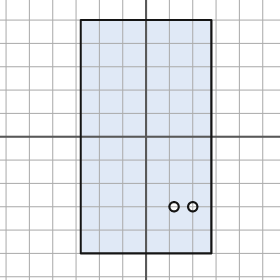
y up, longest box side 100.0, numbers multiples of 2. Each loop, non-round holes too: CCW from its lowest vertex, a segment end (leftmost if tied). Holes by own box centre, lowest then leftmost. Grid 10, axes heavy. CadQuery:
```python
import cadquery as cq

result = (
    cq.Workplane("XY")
    .moveTo(-28.0, -50.0)
    .lineTo(28.0, -50.0)
    .lineTo(28.0, 50.0)
    .lineTo(-28.0, 50.0)
    .close()
    .moveTo(12.0, -30.0)
    .circle(2.0)
    .moveTo(20.0, -30.0)
    .circle(2.0)
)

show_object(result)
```